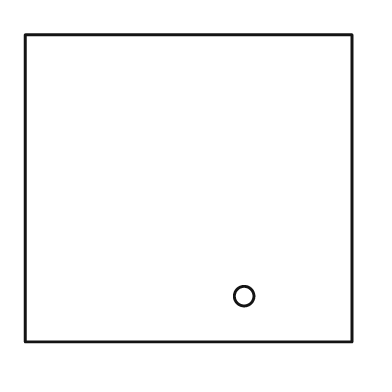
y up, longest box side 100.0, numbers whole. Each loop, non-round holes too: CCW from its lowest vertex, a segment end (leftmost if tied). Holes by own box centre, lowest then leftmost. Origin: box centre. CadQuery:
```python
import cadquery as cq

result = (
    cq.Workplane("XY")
    .moveTo(-50.0, -47.0)
    .lineTo(50.0, -47.0)
    .lineTo(50.0, 47.0)
    .lineTo(-50.0, 47.0)
    .close()
    .moveTo(17.0, -33.0)
    .circle(3.0)
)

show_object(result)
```